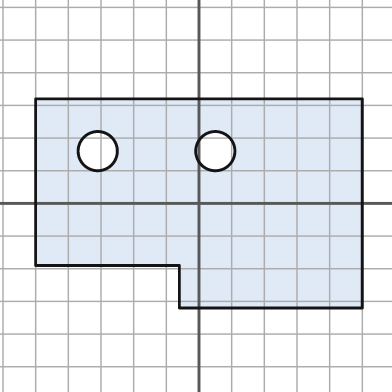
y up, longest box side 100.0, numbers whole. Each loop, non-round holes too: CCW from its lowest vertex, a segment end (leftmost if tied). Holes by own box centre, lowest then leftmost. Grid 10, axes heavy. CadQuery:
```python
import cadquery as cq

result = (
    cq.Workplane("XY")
    .moveTo(-6.0, -32.0)
    .lineTo(50.0, -32.0)
    .lineTo(50.0, 32.0)
    .lineTo(-50.0, 32.0)
    .lineTo(-50.0, -19.0)
    .lineTo(-6.0, -19.0)
    .close()
    .moveTo(-31.0, 16.0)
    .circle(6.0)
    .moveTo(5.0, 16.0)
    .circle(6.0)
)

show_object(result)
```